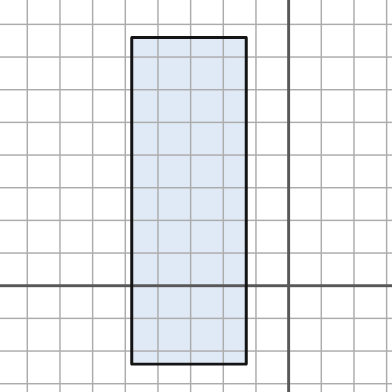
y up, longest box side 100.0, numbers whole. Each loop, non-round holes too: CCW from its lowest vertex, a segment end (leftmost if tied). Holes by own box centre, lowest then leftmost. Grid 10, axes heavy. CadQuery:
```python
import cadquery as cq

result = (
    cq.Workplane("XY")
    .moveTo(-48.0, -24.0)
    .lineTo(-13.0, -24.0)
    .lineTo(-13.0, 76.0)
    .lineTo(-48.0, 76.0)
    .close()
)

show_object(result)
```